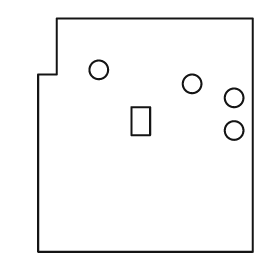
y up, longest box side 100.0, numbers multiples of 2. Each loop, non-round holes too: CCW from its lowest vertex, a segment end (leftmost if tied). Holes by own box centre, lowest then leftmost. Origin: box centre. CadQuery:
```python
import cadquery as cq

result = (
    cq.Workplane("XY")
    .moveTo(-46.0, -50.0)
    .lineTo(46.0, -50.0)
    .lineTo(46.0, 50.0)
    .lineTo(-38.0, 50.0)
    .lineTo(-38.0, 26.0)
    .lineTo(-46.0, 26.0)
    .close()
    .moveTo(38.0, 2.0)
    .circle(4.0)
    .moveTo(-6.0, 0.0)
    .lineTo(2.0, 0.0)
    .lineTo(2.0, 12.0)
    .lineTo(-6.0, 12.0)
    .close()
    .moveTo(38.0, 16.0)
    .circle(4.0)
    .moveTo(20.0, 22.0)
    .circle(4.0)
    .moveTo(-20.0, 28.0)
    .circle(4.0)
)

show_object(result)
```